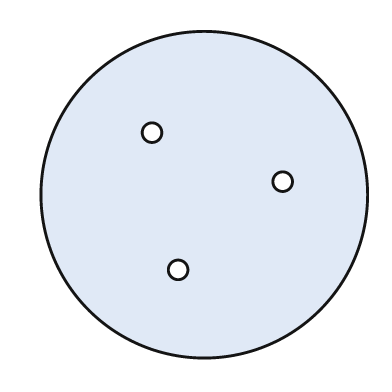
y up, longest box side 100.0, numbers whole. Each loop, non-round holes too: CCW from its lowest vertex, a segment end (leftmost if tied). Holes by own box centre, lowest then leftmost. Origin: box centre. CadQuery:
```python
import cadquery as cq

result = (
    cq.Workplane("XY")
    .moveTo(0.0, 0.0)
    .circle(50.0)
    .moveTo(-8.0, -23.0)
    .circle(3.0)
    .moveTo(24.0, 4.0)
    .circle(3.0)
    .moveTo(-16.0, 19.0)
    .circle(3.0)
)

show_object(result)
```